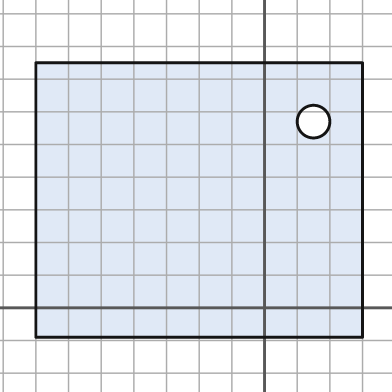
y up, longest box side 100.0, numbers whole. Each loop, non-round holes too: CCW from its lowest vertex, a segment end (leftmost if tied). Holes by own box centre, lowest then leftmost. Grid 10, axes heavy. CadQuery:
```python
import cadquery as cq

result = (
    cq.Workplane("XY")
    .moveTo(-70.0, -9.0)
    .lineTo(30.0, -9.0)
    .lineTo(30.0, 75.0)
    .lineTo(-70.0, 75.0)
    .close()
    .moveTo(15.0, 57.0)
    .circle(5.0)
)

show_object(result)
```